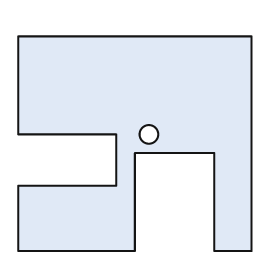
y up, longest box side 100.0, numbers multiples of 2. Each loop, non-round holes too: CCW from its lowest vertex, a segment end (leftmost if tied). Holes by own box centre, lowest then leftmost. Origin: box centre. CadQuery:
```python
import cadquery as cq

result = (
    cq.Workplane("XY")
    .moveTo(-50.0, -46.0)
    .lineTo(0.0, -46.0)
    .lineTo(0.0, -4.0)
    .lineTo(34.0, -4.0)
    .lineTo(34.0, -46.0)
    .lineTo(50.0, -46.0)
    .lineTo(50.0, 46.0)
    .lineTo(-50.0, 46.0)
    .lineTo(-50.0, 4.0)
    .lineTo(-8.0, 4.0)
    .lineTo(-8.0, -18.0)
    .lineTo(-50.0, -18.0)
    .close()
    .moveTo(6.0, 4.0)
    .circle(4.0)
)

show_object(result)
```